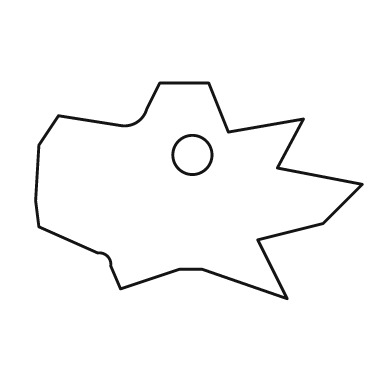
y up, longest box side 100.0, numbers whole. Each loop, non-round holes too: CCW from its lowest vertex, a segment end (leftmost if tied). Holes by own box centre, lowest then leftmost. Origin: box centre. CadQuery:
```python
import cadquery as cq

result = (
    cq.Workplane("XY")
    .moveTo(27.0, -33.0)
    .lineTo(18.0, -15.0)
    .lineTo(38.0, -10.0)
    .lineTo(50.0, 2.0)
    .lineTo(24.0, 7.0)
    .lineTo(32.0, 22.0)
    .lineTo(9.0, 18.0)
    .lineTo(3.0, 33.0)
    .lineTo(-12.0, 33.0)
    .lineTo(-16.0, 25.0)
    .threePointArc((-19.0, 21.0), (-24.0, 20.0))
    .lineTo(-43.0, 23.0)
    .lineTo(-49.0, 14.0)
    .lineTo(-50.0, -3.0)
    .lineTo(-49.0, -11.0)
    .lineTo(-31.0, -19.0)
    .threePointArc((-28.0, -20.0), (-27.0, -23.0))
    .lineTo(-24.0, -30.0)
    .lineTo(-6.0, -24.0)
    .lineTo(1.0, -24.0)
    .close()
    .moveTo(-2.0, 11.0)
    .circle(6.0)
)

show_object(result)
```